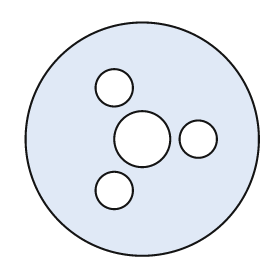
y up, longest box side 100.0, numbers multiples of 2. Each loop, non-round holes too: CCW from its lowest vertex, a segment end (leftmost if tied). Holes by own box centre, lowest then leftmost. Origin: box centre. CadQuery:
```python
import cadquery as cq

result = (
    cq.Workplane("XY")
    .moveTo(0.0, 0.0)
    .circle(50.0)
    .moveTo(-12.0, -22.0)
    .circle(8.0)
    .moveTo(0.0, 0.0)
    .circle(12.0)
    .moveTo(24.0, 0.0)
    .circle(8.0)
    .moveTo(-12.0, 22.0)
    .circle(8.0)
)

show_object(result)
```